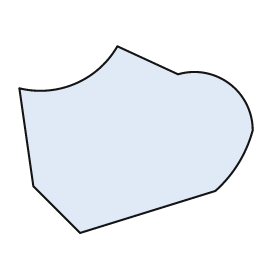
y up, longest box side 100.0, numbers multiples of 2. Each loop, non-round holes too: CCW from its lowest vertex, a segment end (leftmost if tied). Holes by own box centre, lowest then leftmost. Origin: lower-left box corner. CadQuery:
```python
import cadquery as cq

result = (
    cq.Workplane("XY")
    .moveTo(26.0, 0.0)
    .lineTo(84.0, 18.0)
    .threePointArc((94.0, 30.0), (100.0, 44.0))
    .threePointArc((90.0, 64.0), (68.0, 68.0))
    .lineTo(42.0, 80.0)
    .threePointArc((24.0, 64.0), (0.0, 62.0))
    .lineTo(6.0, 20.0)
    .close()
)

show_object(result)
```